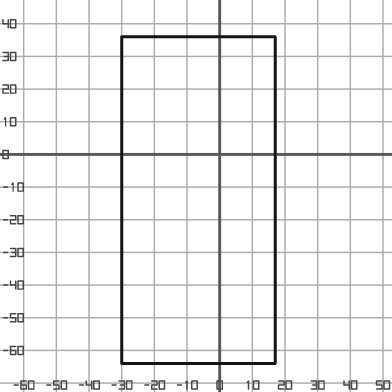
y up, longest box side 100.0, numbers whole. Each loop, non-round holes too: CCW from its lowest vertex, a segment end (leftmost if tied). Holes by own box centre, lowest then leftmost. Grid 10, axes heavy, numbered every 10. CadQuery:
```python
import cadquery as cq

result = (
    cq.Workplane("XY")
    .moveTo(-30.0, -64.0)
    .lineTo(17.0, -64.0)
    .lineTo(17.0, 36.0)
    .lineTo(-30.0, 36.0)
    .close()
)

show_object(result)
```